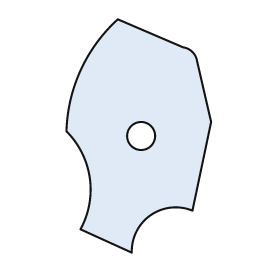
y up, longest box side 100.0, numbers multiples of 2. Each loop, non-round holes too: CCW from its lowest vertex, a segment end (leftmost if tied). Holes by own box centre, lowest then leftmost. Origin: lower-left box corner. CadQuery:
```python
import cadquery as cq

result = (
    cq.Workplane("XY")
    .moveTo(28.0, 0.0)
    .threePointArc((36.0, 16.0), (54.0, 18.0))
    .lineTo(62.0, 56.0)
    .lineTo(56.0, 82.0)
    .threePointArc((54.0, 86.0), (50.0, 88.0))
    .lineTo(22.0, 100.0)
    .threePointArc((6.0, 78.0), (0.0, 52.0))
    .threePointArc((10.0, 32.0), (6.0, 10.0))
    .close()
    .moveTo(32.0, 50.0)
    .circle(6.0)
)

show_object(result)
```